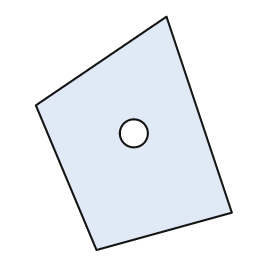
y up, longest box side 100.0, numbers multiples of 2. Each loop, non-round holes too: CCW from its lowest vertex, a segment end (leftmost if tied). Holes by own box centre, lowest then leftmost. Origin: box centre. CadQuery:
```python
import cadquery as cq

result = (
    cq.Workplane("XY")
    .moveTo(-16.0, -50.0)
    .lineTo(42.0, -34.0)
    .lineTo(14.0, 50.0)
    .lineTo(-42.0, 12.0)
    .close()
    .moveTo(0.0, 0.0)
    .circle(6.0)
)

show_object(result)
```